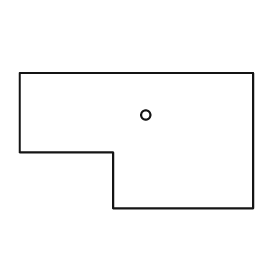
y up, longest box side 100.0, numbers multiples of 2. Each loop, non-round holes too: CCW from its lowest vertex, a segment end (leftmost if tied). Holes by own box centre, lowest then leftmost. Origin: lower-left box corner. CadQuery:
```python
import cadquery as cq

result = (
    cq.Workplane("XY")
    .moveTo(40.0, 0.0)
    .lineTo(100.0, 0.0)
    .lineTo(100.0, 58.0)
    .lineTo(0.0, 58.0)
    .lineTo(0.0, 24.0)
    .lineTo(40.0, 24.0)
    .close()
    .moveTo(54.0, 40.0)
    .circle(2.0)
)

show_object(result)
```